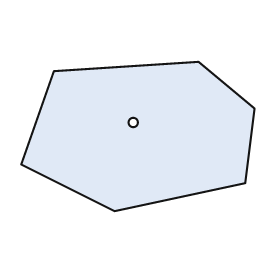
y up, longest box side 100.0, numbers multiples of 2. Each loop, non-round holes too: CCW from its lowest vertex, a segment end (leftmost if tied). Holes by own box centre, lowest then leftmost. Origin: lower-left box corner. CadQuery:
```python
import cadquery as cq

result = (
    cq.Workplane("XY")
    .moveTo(40.0, 0.0)
    .lineTo(96.0, 12.0)
    .lineTo(100.0, 44.0)
    .lineTo(76.0, 64.0)
    .lineTo(14.0, 60.0)
    .lineTo(0.0, 20.0)
    .close()
    .moveTo(48.0, 38.0)
    .circle(2.0)
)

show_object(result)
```